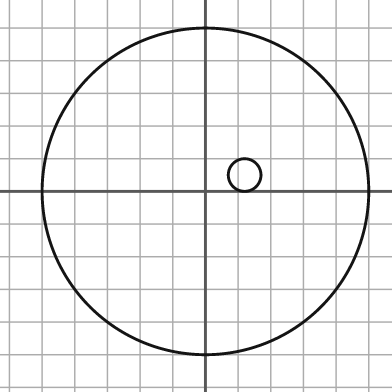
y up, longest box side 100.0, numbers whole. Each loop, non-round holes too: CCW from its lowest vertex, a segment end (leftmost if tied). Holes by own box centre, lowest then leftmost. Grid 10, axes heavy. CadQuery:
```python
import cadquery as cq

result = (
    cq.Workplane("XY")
    .moveTo(0.0, 0.0)
    .circle(50.0)
    .moveTo(12.0, 5.0)
    .circle(5.0)
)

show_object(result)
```